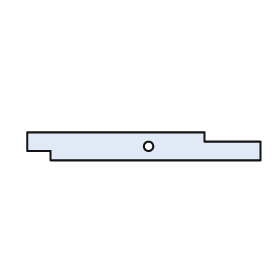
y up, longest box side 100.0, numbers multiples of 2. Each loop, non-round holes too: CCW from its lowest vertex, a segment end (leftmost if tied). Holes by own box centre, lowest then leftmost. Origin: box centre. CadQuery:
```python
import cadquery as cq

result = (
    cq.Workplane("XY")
    .moveTo(-40.0, -6.0)
    .lineTo(50.0, -6.0)
    .lineTo(50.0, 2.0)
    .lineTo(26.0, 2.0)
    .lineTo(26.0, 6.0)
    .lineTo(-50.0, 6.0)
    .lineTo(-50.0, -2.0)
    .lineTo(-40.0, -2.0)
    .close()
    .moveTo(2.0, 0.0)
    .circle(2.0)
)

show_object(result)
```